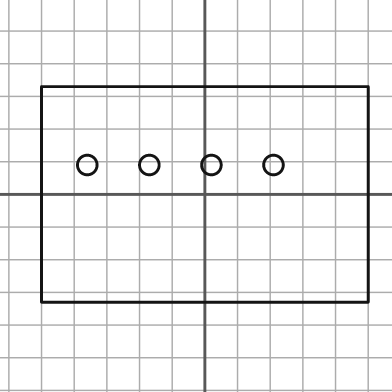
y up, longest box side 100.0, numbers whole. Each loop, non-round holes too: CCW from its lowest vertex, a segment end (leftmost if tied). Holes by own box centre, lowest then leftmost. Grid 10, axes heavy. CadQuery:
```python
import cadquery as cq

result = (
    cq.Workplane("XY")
    .moveTo(-50.0, -33.0)
    .lineTo(50.0, -33.0)
    .lineTo(50.0, 33.0)
    .lineTo(-50.0, 33.0)
    .close()
    .moveTo(-36.0, 9.0)
    .circle(3.0)
    .moveTo(-17.0, 9.0)
    .circle(3.0)
    .moveTo(2.0, 9.0)
    .circle(3.0)
    .moveTo(21.0, 9.0)
    .circle(3.0)
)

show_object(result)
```